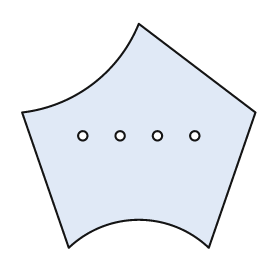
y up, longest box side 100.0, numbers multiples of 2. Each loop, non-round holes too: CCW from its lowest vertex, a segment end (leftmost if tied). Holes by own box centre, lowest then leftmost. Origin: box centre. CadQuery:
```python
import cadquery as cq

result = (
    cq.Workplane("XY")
    .moveTo(-30.0, -48.0)
    .threePointArc((0.0, -36.0), (30.0, -48.0))
    .lineTo(50.0, 10.0)
    .lineTo(0.0, 48.0)
    .threePointArc((-20.0, 22.0), (-50.0, 10.0))
    .close()
    .moveTo(-24.0, 0.0)
    .circle(2.0)
    .moveTo(-8.0, 0.0)
    .circle(2.0)
    .moveTo(8.0, 0.0)
    .circle(2.0)
    .moveTo(24.0, 0.0)
    .circle(2.0)
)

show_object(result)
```